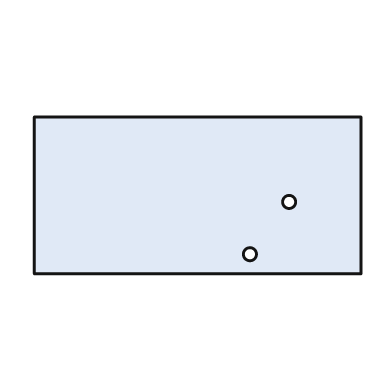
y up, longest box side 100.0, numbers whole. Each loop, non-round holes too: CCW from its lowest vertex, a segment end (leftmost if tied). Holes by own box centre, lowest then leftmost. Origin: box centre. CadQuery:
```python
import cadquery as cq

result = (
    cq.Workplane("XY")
    .moveTo(-50.0, -24.0)
    .lineTo(50.0, -24.0)
    .lineTo(50.0, 24.0)
    .lineTo(-50.0, 24.0)
    .close()
    .moveTo(16.0, -18.0)
    .circle(2.0)
    .moveTo(28.0, -2.0)
    .circle(2.0)
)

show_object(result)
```